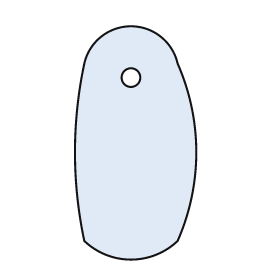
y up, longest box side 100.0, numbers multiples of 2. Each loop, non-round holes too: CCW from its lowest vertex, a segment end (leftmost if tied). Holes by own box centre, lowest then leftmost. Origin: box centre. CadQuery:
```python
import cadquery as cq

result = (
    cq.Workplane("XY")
    .moveTo(-22.0, -42.0)
    .threePointArc((-2.0, -50.0), (18.0, -42.0))
    .threePointArc((26.0, -4.0), (18.0, 34.0))
    .threePointArc((-2.0, 50.0), (-22.0, 34.0))
    .threePointArc((-26.0, -4.0), (-22.0, -42.0))
    .close()
    .moveTo(-2.0, 28.0)
    .circle(4.0)
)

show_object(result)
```